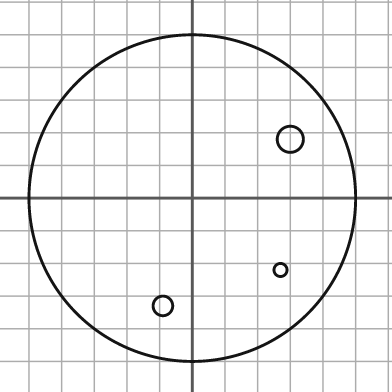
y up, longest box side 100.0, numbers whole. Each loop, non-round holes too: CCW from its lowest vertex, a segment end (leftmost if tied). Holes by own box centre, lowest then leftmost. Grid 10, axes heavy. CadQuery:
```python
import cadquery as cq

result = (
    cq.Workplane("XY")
    .moveTo(0.0, 0.0)
    .circle(50.0)
    .moveTo(-9.0, -33.0)
    .circle(3.0)
    .moveTo(27.0, -22.0)
    .circle(2.0)
    .moveTo(30.0, 18.0)
    .circle(4.0)
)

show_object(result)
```